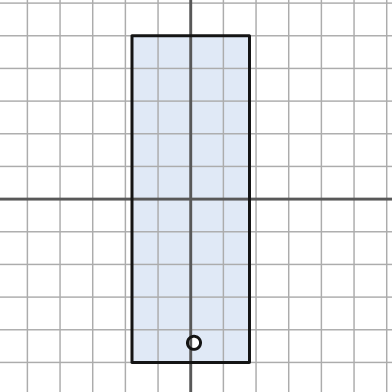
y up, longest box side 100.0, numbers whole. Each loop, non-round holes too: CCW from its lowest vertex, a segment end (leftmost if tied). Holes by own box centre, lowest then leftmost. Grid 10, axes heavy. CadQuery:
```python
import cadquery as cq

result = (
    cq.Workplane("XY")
    .moveTo(-18.0, -50.0)
    .lineTo(18.0, -50.0)
    .lineTo(18.0, 50.0)
    .lineTo(-18.0, 50.0)
    .close()
    .moveTo(1.0, -44.0)
    .circle(2.0)
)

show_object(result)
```